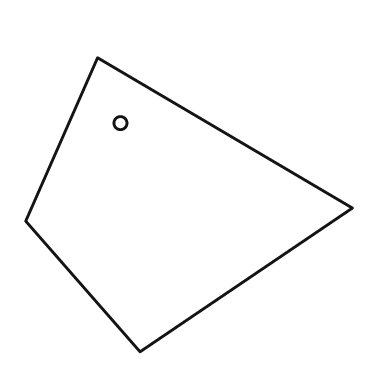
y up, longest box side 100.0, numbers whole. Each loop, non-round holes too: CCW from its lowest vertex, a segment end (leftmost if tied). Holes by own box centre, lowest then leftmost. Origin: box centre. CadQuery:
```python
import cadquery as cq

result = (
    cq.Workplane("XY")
    .moveTo(-15.0, -45.0)
    .lineTo(50.0, -1.0)
    .lineTo(-28.0, 45.0)
    .lineTo(-50.0, -5.0)
    .close()
    .moveTo(-21.0, 25.0)
    .circle(2.0)
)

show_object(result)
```